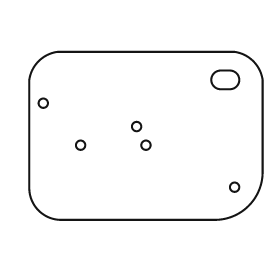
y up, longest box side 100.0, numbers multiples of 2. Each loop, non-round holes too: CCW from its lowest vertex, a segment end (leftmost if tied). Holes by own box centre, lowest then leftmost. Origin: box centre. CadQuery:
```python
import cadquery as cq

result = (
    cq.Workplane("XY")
    .moveTo(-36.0, -36.0)
    .lineTo(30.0, -36.0)
    .threePointArc((44.0, -30.0), (50.0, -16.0))
    .lineTo(50.0, 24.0)
    .threePointArc((46.0, 32.0), (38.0, 36.0))
    .lineTo(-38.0, 36.0)
    .threePointArc((-46.0, 32.0), (-50.0, 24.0))
    .lineTo(-50.0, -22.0)
    .threePointArc((-46.0, -32.0), (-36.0, -36.0))
    .close()
    .moveTo(38.0, -22.0)
    .circle(2.0)
    .moveTo(-28.0, -4.0)
    .circle(2.0)
    .moveTo(0.0, -4.0)
    .circle(2.0)
    .moveTo(-4.0, 4.0)
    .circle(2.0)
    .moveTo(-44.0, 14.0)
    .circle(2.0)
    .moveTo(32.0, 20.0)
    .lineTo(36.0, 20.0)
    .threePointArc((40.0, 24.0), (36.0, 28.0))
    .lineTo(32.0, 28.0)
    .threePointArc((28.0, 24.0), (32.0, 20.0))
    .close()
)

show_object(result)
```